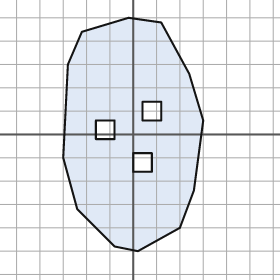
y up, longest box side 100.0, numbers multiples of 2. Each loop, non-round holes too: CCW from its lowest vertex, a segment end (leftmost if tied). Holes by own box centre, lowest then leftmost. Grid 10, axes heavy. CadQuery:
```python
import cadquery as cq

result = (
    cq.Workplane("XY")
    .moveTo(2.0, -50.0)
    .lineTo(20.0, -40.0)
    .lineTo(26.0, -24.0)
    .lineTo(30.0, 6.0)
    .lineTo(24.0, 26.0)
    .lineTo(12.0, 48.0)
    .lineTo(-2.0, 50.0)
    .lineTo(-22.0, 44.0)
    .lineTo(-28.0, 30.0)
    .lineTo(-30.0, -10.0)
    .lineTo(-24.0, -32.0)
    .lineTo(-8.0, -48.0)
    .close()
    .moveTo(0.0, -16.0)
    .lineTo(8.0, -16.0)
    .lineTo(8.0, -8.0)
    .lineTo(0.0, -8.0)
    .close()
    .moveTo(-16.0, -2.0)
    .lineTo(-8.0, -2.0)
    .lineTo(-8.0, 6.0)
    .lineTo(-16.0, 6.0)
    .close()
    .moveTo(4.0, 6.0)
    .lineTo(12.0, 6.0)
    .lineTo(12.0, 14.0)
    .lineTo(4.0, 14.0)
    .close()
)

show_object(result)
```